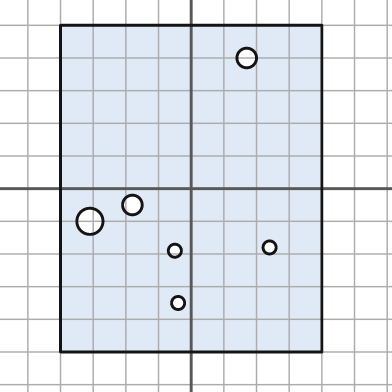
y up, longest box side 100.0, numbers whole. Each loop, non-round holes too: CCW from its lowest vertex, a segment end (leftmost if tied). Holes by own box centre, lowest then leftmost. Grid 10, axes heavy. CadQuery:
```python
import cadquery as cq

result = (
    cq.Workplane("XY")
    .moveTo(-40.0, -50.0)
    .lineTo(40.0, -50.0)
    .lineTo(40.0, 50.0)
    .lineTo(-40.0, 50.0)
    .close()
    .moveTo(-4.0, -35.0)
    .circle(2.0)
    .moveTo(-5.0, -19.0)
    .circle(2.0)
    .moveTo(24.0, -18.0)
    .circle(2.0)
    .moveTo(-31.0, -10.0)
    .circle(4.0)
    .moveTo(-18.0, -5.0)
    .circle(3.0)
    .moveTo(17.0, 40.0)
    .circle(3.0)
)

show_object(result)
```